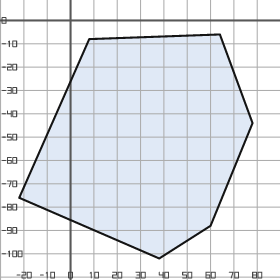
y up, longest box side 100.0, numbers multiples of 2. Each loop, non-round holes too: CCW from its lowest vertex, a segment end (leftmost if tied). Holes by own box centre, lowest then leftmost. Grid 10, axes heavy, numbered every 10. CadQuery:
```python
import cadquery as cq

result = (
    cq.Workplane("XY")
    .moveTo(38.0, -102.0)
    .lineTo(60.0, -88.0)
    .lineTo(78.0, -44.0)
    .lineTo(64.0, -6.0)
    .lineTo(8.0, -8.0)
    .lineTo(-22.0, -76.0)
    .close()
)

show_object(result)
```